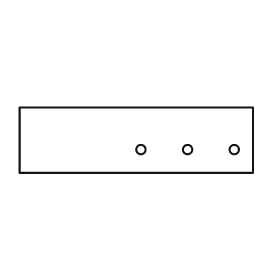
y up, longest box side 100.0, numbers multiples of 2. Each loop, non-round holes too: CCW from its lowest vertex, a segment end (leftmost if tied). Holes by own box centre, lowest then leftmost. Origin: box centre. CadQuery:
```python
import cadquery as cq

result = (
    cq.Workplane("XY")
    .moveTo(-50.0, -14.0)
    .lineTo(50.0, -14.0)
    .lineTo(50.0, 14.0)
    .lineTo(-50.0, 14.0)
    .close()
    .moveTo(2.0, -4.0)
    .circle(2.0)
    .moveTo(22.0, -4.0)
    .circle(2.0)
    .moveTo(42.0, -4.0)
    .circle(2.0)
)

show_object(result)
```